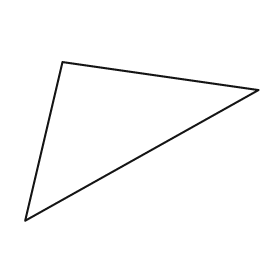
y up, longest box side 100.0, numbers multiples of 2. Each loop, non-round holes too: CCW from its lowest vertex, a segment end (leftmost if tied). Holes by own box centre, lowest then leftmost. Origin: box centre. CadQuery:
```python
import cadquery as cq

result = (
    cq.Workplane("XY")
    .moveTo(-50.0, -34.0)
    .lineTo(50.0, 22.0)
    .lineTo(-34.0, 34.0)
    .close()
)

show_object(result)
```